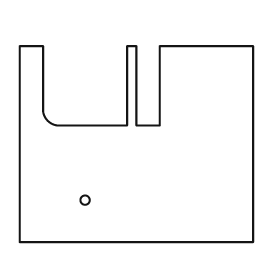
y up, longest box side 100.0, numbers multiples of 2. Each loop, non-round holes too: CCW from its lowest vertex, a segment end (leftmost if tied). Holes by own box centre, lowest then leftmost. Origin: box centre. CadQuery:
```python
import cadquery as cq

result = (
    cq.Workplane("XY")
    .moveTo(-50.0, -42.0)
    .lineTo(50.0, -42.0)
    .lineTo(50.0, 42.0)
    .lineTo(10.0, 42.0)
    .lineTo(10.0, 8.0)
    .lineTo(0.0, 8.0)
    .lineTo(0.0, 42.0)
    .lineTo(-4.0, 42.0)
    .lineTo(-4.0, 8.0)
    .lineTo(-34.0, 8.0)
    .threePointArc((-38.0, 10.0), (-40.0, 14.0))
    .lineTo(-40.0, 42.0)
    .lineTo(-50.0, 42.0)
    .close()
    .moveTo(-22.0, -24.0)
    .circle(2.0)
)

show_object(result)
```